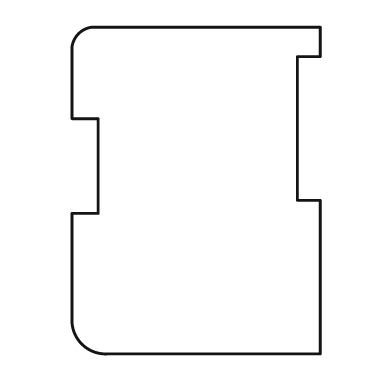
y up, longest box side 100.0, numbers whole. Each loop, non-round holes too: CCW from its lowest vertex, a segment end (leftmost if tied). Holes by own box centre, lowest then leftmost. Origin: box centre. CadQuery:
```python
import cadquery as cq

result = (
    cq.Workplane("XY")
    .moveTo(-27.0, -50.0)
    .lineTo(38.0, -50.0)
    .lineTo(38.0, -3.0)
    .lineTo(31.0, -3.0)
    .lineTo(31.0, 41.0)
    .lineTo(38.0, 41.0)
    .lineTo(38.0, 50.0)
    .lineTo(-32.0, 50.0)
    .threePointArc((-36.0, 48.0), (-38.0, 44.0))
    .lineTo(-38.0, 22.0)
    .lineTo(-30.0, 22.0)
    .lineTo(-30.0, -7.0)
    .lineTo(-38.0, -7.0)
    .lineTo(-38.0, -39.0)
    .threePointArc((-35.0, -47.0), (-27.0, -50.0))
    .close()
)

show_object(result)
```